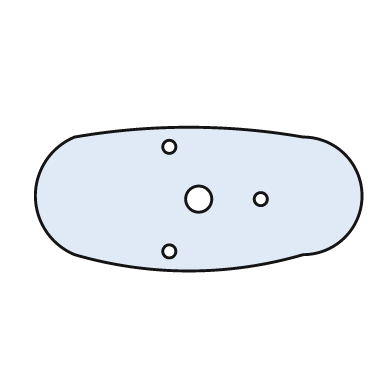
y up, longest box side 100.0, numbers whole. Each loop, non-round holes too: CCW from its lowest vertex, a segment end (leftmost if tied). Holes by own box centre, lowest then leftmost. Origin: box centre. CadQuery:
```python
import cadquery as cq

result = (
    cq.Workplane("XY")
    .moveTo(-38.0, -17.0)
    .threePointArc((-3.0, -22.0), (32.0, -17.0))
    .threePointArc((50.0, 1.0), (32.0, 19.0))
    .threePointArc((-3.0, 22.0), (-38.0, 19.0))
    .threePointArc((-50.0, 1.0), (-38.0, -17.0))
    .close()
    .moveTo(-9.0, -16.0)
    .circle(2.0)
    .moveTo(0.0, 0.0)
    .circle(4.0)
    .moveTo(19.0, 0.0)
    .circle(2.0)
    .moveTo(-9.0, 16.0)
    .circle(2.0)
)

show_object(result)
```